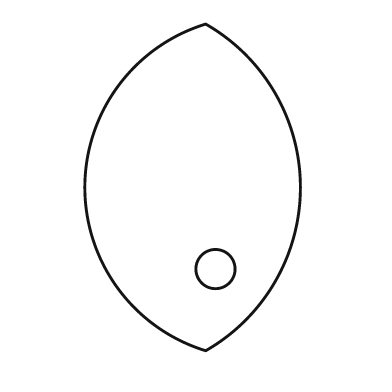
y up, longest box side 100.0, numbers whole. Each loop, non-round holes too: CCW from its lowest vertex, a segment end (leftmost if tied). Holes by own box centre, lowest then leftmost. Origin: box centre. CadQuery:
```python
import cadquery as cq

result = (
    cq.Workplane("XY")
    .moveTo(4.0, -50.0)
    .threePointArc((33.0, 0.0), (4.0, 50.0))
    .threePointArc((-33.0, 0.0), (4.0, -50.0))
    .close()
    .moveTo(7.0, -25.0)
    .circle(6.0)
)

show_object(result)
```